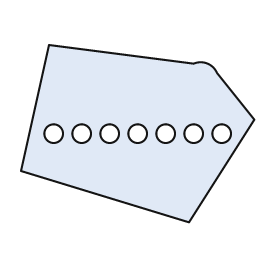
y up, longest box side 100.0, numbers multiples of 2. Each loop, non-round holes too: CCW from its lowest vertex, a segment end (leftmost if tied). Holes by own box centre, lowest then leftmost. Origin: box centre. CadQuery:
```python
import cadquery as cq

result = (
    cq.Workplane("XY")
    .moveTo(22.0, -38.0)
    .lineTo(50.0, 6.0)
    .lineTo(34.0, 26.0)
    .threePointArc((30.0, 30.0), (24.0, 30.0))
    .lineTo(-38.0, 38.0)
    .lineTo(-50.0, -16.0)
    .close()
    .moveTo(-36.0, 0.0)
    .circle(4.0)
    .moveTo(-24.0, 0.0)
    .circle(4.0)
    .moveTo(-12.0, 0.0)
    .circle(4.0)
    .moveTo(0.0, 0.0)
    .circle(4.0)
    .moveTo(12.0, 0.0)
    .circle(4.0)
    .moveTo(24.0, 0.0)
    .circle(4.0)
    .moveTo(36.0, 0.0)
    .circle(4.0)
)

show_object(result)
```